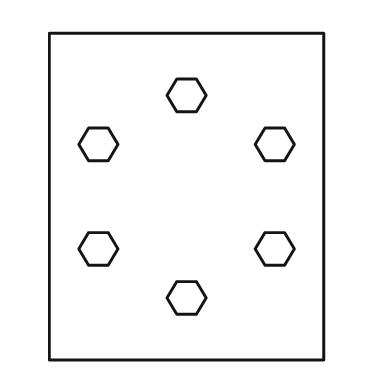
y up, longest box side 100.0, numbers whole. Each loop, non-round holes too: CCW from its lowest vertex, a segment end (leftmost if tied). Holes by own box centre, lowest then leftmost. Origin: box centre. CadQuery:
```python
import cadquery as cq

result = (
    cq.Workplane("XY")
    .moveTo(-42.0, -50.0)
    .lineTo(42.0, -50.0)
    .lineTo(42.0, 50.0)
    .lineTo(-42.0, 50.0)
    .close()
    .moveTo(-3.0, -36.0)
    .lineTo(3.0, -36.0)
    .lineTo(6.0, -31.0)
    .lineTo(3.0, -26.0)
    .lineTo(-3.0, -26.0)
    .lineTo(-6.0, -31.0)
    .close()
    .moveTo(-30.0, -21.0)
    .lineTo(-24.0, -21.0)
    .lineTo(-21.0, -16.0)
    .lineTo(-24.0, -11.0)
    .lineTo(-30.0, -11.0)
    .lineTo(-33.0, -16.0)
    .close()
    .moveTo(24.0, -21.0)
    .lineTo(30.0, -21.0)
    .lineTo(33.0, -16.0)
    .lineTo(30.0, -11.0)
    .lineTo(24.0, -11.0)
    .lineTo(21.0, -16.0)
    .close()
    .moveTo(-30.0, 11.0)
    .lineTo(-24.0, 11.0)
    .lineTo(-21.0, 16.0)
    .lineTo(-24.0, 21.0)
    .lineTo(-30.0, 21.0)
    .lineTo(-33.0, 16.0)
    .close()
    .moveTo(24.0, 11.0)
    .lineTo(30.0, 11.0)
    .lineTo(33.0, 16.0)
    .lineTo(30.0, 21.0)
    .lineTo(24.0, 21.0)
    .lineTo(21.0, 16.0)
    .close()
    .moveTo(-3.0, 26.0)
    .lineTo(3.0, 26.0)
    .lineTo(6.0, 31.0)
    .lineTo(3.0, 36.0)
    .lineTo(-3.0, 36.0)
    .lineTo(-6.0, 31.0)
    .close()
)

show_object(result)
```